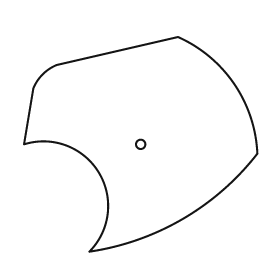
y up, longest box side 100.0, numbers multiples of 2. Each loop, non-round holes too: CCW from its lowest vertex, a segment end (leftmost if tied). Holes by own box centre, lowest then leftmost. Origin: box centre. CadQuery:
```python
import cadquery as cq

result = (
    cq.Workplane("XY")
    .moveTo(-22.0, -46.0)
    .threePointArc((18.0, -32.0), (50.0, -4.0))
    .threePointArc((40.0, 26.0), (16.0, 46.0))
    .lineTo(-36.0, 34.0)
    .threePointArc((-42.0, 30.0), (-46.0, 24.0))
    .lineTo(-50.0, 0.0)
    .threePointArc((-18.0, -12.0), (-22.0, -46.0))
    .close()
    .moveTo(0.0, 0.0)
    .circle(2.0)
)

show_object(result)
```